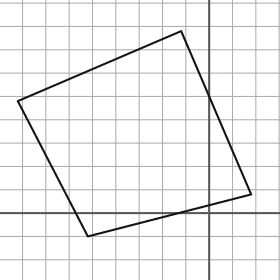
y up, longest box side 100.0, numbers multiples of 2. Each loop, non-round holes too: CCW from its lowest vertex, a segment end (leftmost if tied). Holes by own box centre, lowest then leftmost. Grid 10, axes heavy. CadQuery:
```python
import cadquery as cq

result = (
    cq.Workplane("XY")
    .moveTo(-52.0, -10.0)
    .lineTo(18.0, 8.0)
    .lineTo(-12.0, 78.0)
    .lineTo(-82.0, 48.0)
    .close()
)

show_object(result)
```